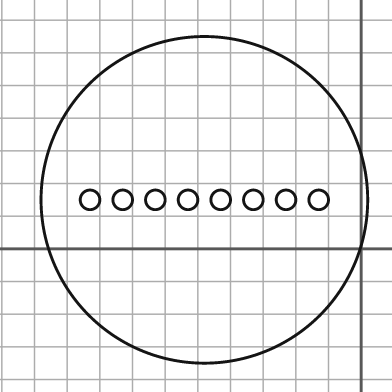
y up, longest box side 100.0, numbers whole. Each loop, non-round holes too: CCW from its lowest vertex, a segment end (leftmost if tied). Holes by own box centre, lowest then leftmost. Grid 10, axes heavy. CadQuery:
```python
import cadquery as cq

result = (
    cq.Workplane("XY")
    .moveTo(-48.0, 15.0)
    .circle(50.0)
    .moveTo(-83.0, 15.0)
    .circle(3.0)
    .moveTo(-73.0, 15.0)
    .circle(3.0)
    .moveTo(-63.0, 15.0)
    .circle(3.0)
    .moveTo(-53.0, 15.0)
    .circle(3.0)
    .moveTo(-43.0, 15.0)
    .circle(3.0)
    .moveTo(-33.0, 15.0)
    .circle(3.0)
    .moveTo(-23.0, 15.0)
    .circle(3.0)
    .moveTo(-13.0, 15.0)
    .circle(3.0)
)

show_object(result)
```